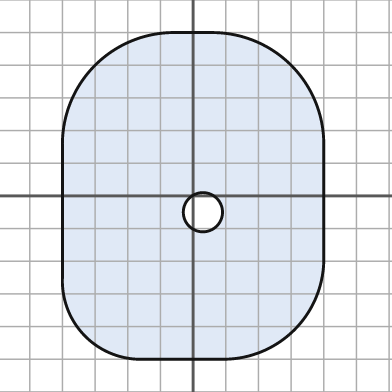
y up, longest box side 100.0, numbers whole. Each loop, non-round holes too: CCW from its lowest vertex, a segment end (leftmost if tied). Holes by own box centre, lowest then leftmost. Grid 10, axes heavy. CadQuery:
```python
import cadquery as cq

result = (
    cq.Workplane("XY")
    .moveTo(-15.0, -50.0)
    .lineTo(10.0, -50.0)
    .threePointArc((31.0, -41.0), (40.0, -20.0))
    .lineTo(40.0, 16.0)
    .threePointArc((30.0, 40.0), (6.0, 50.0))
    .lineTo(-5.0, 50.0)
    .threePointArc((-30.0, 40.0), (-40.0, 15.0))
    .lineTo(-40.0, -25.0)
    .threePointArc((-33.0, -43.0), (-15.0, -50.0))
    .close()
    .moveTo(3.0, -5.0)
    .circle(6.0)
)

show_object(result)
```